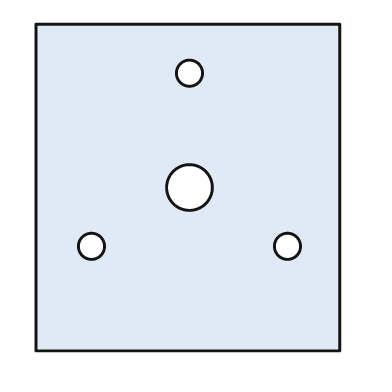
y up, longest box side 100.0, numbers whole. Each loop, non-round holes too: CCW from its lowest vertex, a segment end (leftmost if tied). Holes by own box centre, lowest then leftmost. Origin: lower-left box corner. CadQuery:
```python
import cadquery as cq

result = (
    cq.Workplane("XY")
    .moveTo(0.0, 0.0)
    .lineTo(93.0, 0.0)
    .lineTo(93.0, 100.0)
    .lineTo(0.0, 100.0)
    .close()
    .moveTo(17.0, 32.0)
    .circle(4.0)
    .moveTo(77.0, 32.0)
    .circle(4.0)
    .moveTo(47.0, 50.0)
    .circle(7.0)
    .moveTo(47.0, 85.0)
    .circle(4.0)
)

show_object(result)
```